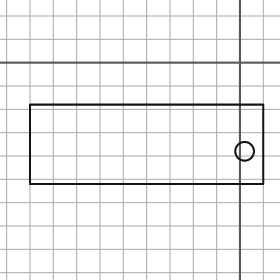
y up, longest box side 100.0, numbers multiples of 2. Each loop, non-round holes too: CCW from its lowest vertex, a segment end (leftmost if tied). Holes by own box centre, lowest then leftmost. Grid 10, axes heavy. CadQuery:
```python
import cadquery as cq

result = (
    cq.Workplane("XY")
    .moveTo(-90.0, -52.0)
    .lineTo(10.0, -52.0)
    .lineTo(10.0, -18.0)
    .lineTo(-90.0, -18.0)
    .close()
    .moveTo(2.0, -38.0)
    .circle(4.0)
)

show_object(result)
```